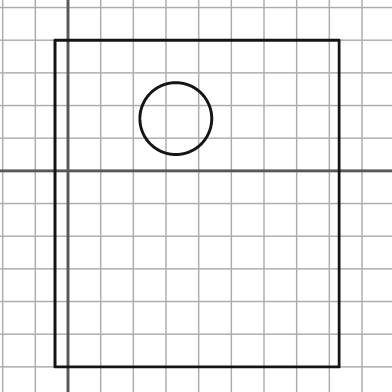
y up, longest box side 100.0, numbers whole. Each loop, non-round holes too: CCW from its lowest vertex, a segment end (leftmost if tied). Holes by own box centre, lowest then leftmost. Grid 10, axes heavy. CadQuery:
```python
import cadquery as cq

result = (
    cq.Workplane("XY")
    .moveTo(-4.0, -60.0)
    .lineTo(83.0, -60.0)
    .lineTo(83.0, 40.0)
    .lineTo(-4.0, 40.0)
    .close()
    .moveTo(33.0, 16.0)
    .circle(11.0)
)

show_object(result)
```